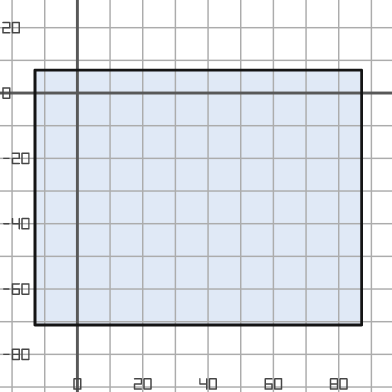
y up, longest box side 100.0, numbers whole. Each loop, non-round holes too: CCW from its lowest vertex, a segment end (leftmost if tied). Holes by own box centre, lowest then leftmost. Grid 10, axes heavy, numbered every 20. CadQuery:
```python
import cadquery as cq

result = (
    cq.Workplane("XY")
    .moveTo(-13.0, -71.0)
    .lineTo(87.0, -71.0)
    .lineTo(87.0, 7.0)
    .lineTo(-13.0, 7.0)
    .close()
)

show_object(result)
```